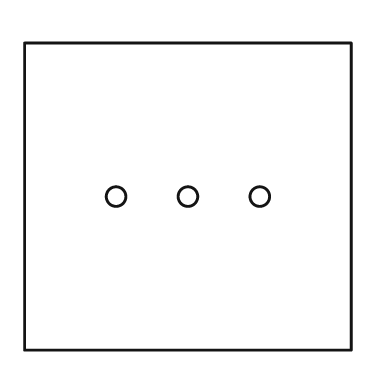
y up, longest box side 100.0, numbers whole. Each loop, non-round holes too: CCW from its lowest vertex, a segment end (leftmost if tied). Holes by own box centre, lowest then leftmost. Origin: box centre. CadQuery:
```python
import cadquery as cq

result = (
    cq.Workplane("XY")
    .moveTo(-50.0, -47.0)
    .lineTo(50.0, -47.0)
    .lineTo(50.0, 47.0)
    .lineTo(-50.0, 47.0)
    .close()
    .moveTo(-22.0, 0.0)
    .circle(3.0)
    .moveTo(0.0, 0.0)
    .circle(3.0)
    .moveTo(22.0, 0.0)
    .circle(3.0)
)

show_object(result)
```